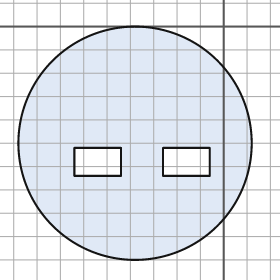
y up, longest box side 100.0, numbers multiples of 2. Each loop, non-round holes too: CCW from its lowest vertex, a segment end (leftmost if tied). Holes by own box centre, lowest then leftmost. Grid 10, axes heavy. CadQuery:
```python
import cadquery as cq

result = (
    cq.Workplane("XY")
    .moveTo(-38.0, -50.0)
    .circle(50.0)
    .moveTo(-64.0, -64.0)
    .lineTo(-44.0, -64.0)
    .lineTo(-44.0, -52.0)
    .lineTo(-64.0, -52.0)
    .close()
    .moveTo(-26.0, -64.0)
    .lineTo(-6.0, -64.0)
    .lineTo(-6.0, -52.0)
    .lineTo(-26.0, -52.0)
    .close()
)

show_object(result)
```